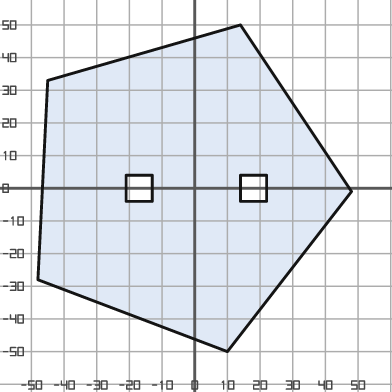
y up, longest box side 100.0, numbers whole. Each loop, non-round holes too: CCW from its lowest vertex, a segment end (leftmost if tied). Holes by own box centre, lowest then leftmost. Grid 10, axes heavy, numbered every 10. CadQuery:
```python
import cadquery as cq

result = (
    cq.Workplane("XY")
    .moveTo(10.0, -50.0)
    .lineTo(48.0, -1.0)
    .lineTo(14.0, 50.0)
    .lineTo(-45.0, 33.0)
    .lineTo(-48.0, -28.0)
    .close()
    .moveTo(-21.0, -4.0)
    .lineTo(-13.0, -4.0)
    .lineTo(-13.0, 4.0)
    .lineTo(-21.0, 4.0)
    .close()
    .moveTo(14.0, -4.0)
    .lineTo(22.0, -4.0)
    .lineTo(22.0, 4.0)
    .lineTo(14.0, 4.0)
    .close()
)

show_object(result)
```